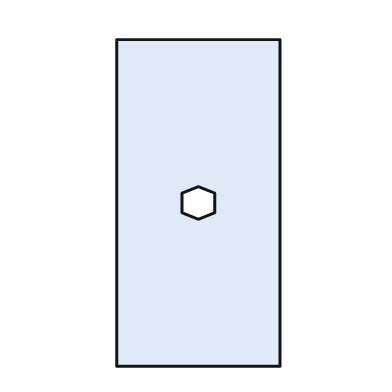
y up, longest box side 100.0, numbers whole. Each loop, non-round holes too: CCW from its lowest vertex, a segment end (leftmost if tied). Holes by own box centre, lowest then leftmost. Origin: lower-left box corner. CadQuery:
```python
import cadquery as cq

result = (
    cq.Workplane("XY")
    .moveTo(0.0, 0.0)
    .lineTo(50.0, 0.0)
    .lineTo(50.0, 100.0)
    .lineTo(0.0, 100.0)
    .close()
    .moveTo(25.0, 45.0)
    .lineTo(30.0, 47.0)
    .lineTo(30.0, 53.0)
    .lineTo(25.0, 55.0)
    .lineTo(20.0, 53.0)
    .lineTo(20.0, 47.0)
    .close()
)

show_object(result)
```